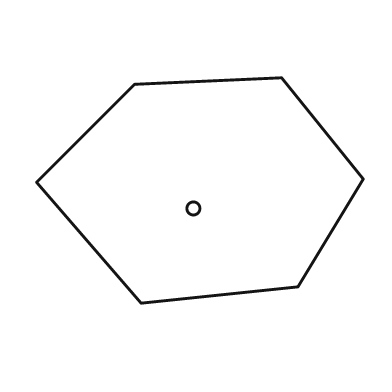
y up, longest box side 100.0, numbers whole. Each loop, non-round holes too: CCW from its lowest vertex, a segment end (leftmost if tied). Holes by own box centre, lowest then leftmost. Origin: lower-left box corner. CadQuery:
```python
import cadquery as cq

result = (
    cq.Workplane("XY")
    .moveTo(32.0, 0.0)
    .lineTo(80.0, 5.0)
    .lineTo(100.0, 38.0)
    .lineTo(75.0, 69.0)
    .lineTo(30.0, 67.0)
    .lineTo(0.0, 37.0)
    .close()
    .moveTo(48.0, 29.0)
    .circle(2.0)
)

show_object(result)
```